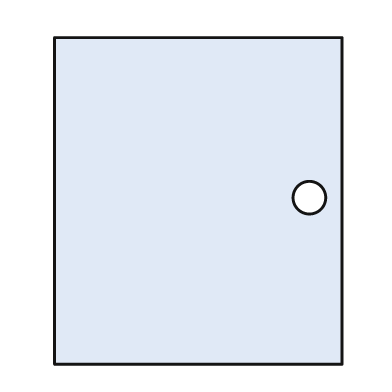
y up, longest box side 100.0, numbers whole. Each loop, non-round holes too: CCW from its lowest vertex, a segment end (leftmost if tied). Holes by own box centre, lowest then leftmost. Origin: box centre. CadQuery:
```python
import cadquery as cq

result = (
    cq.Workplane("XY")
    .moveTo(-44.0, -50.0)
    .lineTo(44.0, -50.0)
    .lineTo(44.0, 50.0)
    .lineTo(-44.0, 50.0)
    .close()
    .moveTo(34.0, 1.0)
    .circle(5.0)
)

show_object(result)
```